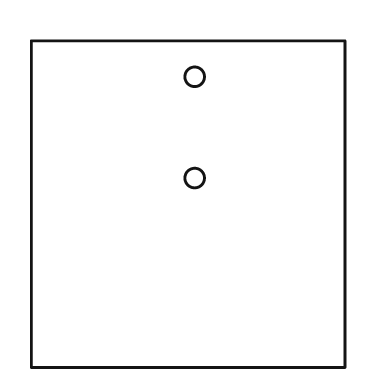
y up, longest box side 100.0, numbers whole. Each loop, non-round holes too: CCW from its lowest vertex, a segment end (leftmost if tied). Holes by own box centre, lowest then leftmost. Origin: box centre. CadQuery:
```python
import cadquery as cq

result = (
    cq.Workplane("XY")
    .moveTo(-48.0, -50.0)
    .lineTo(48.0, -50.0)
    .lineTo(48.0, 50.0)
    .lineTo(-48.0, 50.0)
    .close()
    .moveTo(2.0, 8.0)
    .circle(3.0)
    .moveTo(2.0, 39.0)
    .circle(3.0)
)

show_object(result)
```